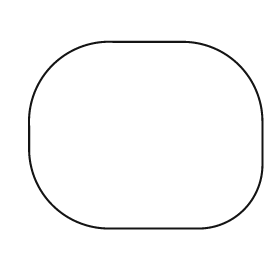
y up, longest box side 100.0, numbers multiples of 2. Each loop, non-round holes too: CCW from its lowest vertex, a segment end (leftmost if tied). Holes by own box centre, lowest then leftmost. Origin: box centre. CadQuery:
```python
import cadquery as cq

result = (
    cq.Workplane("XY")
    .moveTo(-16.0, -40.0)
    .lineTo(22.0, -40.0)
    .threePointArc((42.0, -32.0), (50.0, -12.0))
    .lineTo(50.0, 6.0)
    .threePointArc((40.0, 30.0), (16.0, 40.0))
    .lineTo(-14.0, 40.0)
    .threePointArc((-40.0, 30.0), (-50.0, 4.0))
    .lineTo(-50.0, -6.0)
    .threePointArc((-40.0, -30.0), (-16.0, -40.0))
    .close()
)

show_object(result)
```